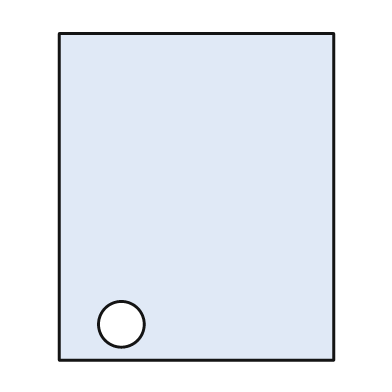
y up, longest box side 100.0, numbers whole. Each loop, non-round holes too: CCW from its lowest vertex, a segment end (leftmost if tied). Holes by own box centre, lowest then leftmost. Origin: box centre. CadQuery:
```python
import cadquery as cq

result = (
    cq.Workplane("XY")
    .moveTo(-42.0, -50.0)
    .lineTo(42.0, -50.0)
    .lineTo(42.0, 50.0)
    .lineTo(-42.0, 50.0)
    .close()
    .moveTo(-23.0, -39.0)
    .circle(7.0)
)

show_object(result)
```